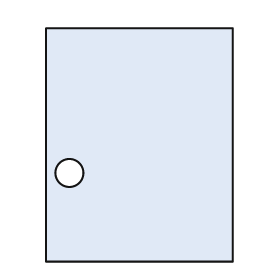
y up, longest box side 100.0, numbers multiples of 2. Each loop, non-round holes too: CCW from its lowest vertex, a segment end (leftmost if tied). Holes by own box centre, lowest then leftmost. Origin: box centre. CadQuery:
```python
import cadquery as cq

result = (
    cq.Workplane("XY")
    .moveTo(-40.0, -50.0)
    .lineTo(40.0, -50.0)
    .lineTo(40.0, 50.0)
    .lineTo(-40.0, 50.0)
    .close()
    .moveTo(-30.0, -12.0)
    .circle(6.0)
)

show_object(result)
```